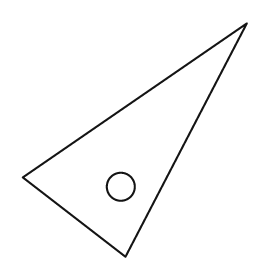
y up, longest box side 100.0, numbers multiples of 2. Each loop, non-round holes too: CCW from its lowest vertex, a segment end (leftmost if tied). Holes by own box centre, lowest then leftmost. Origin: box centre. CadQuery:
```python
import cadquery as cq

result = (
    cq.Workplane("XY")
    .moveTo(-4.0, -50.0)
    .lineTo(48.0, 50.0)
    .lineTo(-48.0, -16.0)
    .close()
    .moveTo(-6.0, -20.0)
    .circle(6.0)
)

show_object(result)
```